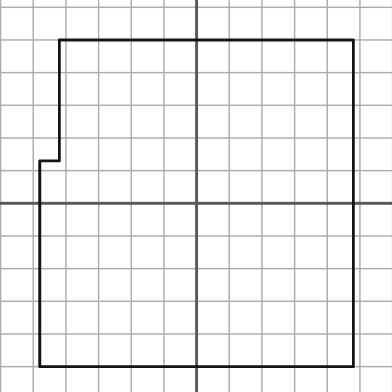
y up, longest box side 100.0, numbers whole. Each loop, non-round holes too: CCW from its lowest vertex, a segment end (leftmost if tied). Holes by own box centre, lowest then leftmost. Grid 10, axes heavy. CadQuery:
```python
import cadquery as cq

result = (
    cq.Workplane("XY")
    .moveTo(-48.0, -50.0)
    .lineTo(48.0, -50.0)
    .lineTo(48.0, 50.0)
    .lineTo(-42.0, 50.0)
    .lineTo(-42.0, 13.0)
    .lineTo(-48.0, 13.0)
    .close()
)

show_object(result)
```